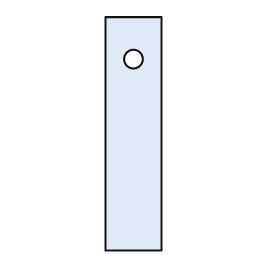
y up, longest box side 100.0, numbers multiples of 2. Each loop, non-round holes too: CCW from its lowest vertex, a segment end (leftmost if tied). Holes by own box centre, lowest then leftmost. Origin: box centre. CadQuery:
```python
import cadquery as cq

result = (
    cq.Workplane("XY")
    .moveTo(-12.0, -50.0)
    .lineTo(12.0, -50.0)
    .lineTo(12.0, 50.0)
    .lineTo(-12.0, 50.0)
    .close()
    .moveTo(0.0, 32.0)
    .circle(4.0)
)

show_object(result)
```